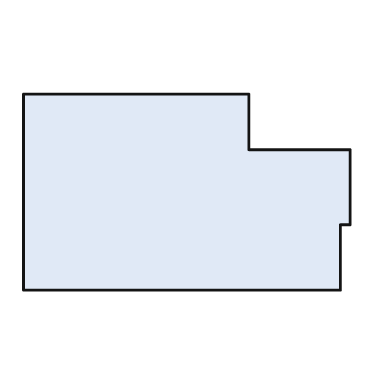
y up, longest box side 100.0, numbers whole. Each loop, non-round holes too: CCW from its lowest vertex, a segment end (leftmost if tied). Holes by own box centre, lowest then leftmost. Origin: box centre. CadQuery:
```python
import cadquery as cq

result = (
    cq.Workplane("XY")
    .moveTo(-50.0, -30.0)
    .lineTo(47.0, -30.0)
    .lineTo(47.0, -10.0)
    .lineTo(50.0, -10.0)
    .lineTo(50.0, 13.0)
    .lineTo(19.0, 13.0)
    .lineTo(19.0, 30.0)
    .lineTo(-50.0, 30.0)
    .close()
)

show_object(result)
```